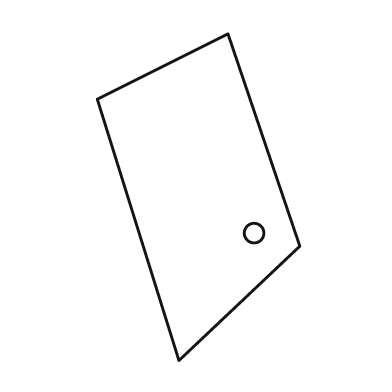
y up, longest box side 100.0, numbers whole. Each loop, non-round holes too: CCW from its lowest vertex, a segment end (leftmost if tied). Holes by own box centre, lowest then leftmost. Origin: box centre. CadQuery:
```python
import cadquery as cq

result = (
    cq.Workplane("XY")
    .moveTo(-6.0, -50.0)
    .lineTo(31.0, -15.0)
    .lineTo(9.0, 50.0)
    .lineTo(-31.0, 30.0)
    .close()
    .moveTo(17.0, -11.0)
    .circle(3.0)
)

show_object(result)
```